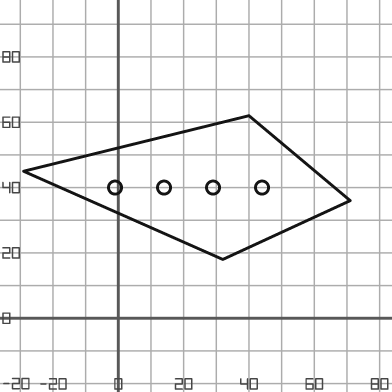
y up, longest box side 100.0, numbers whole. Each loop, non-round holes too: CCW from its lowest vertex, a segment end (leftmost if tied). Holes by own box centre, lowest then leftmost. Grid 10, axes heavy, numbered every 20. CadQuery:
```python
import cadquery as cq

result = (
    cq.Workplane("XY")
    .moveTo(32.0, 18.0)
    .lineTo(71.0, 36.0)
    .lineTo(40.0, 62.0)
    .lineTo(-29.0, 45.0)
    .close()
    .moveTo(-1.0, 40.0)
    .circle(2.0)
    .moveTo(14.0, 40.0)
    .circle(2.0)
    .moveTo(29.0, 40.0)
    .circle(2.0)
    .moveTo(44.0, 40.0)
    .circle(2.0)
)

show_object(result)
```